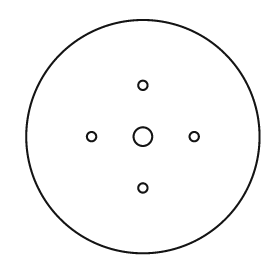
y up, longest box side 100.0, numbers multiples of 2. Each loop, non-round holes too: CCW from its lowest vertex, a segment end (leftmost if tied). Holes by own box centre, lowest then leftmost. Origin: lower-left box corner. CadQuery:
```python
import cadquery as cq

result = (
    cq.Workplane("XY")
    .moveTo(50.0, 50.0)
    .circle(50.0)
    .moveTo(50.0, 28.0)
    .circle(2.0)
    .moveTo(28.0, 50.0)
    .circle(2.0)
    .moveTo(50.0, 50.0)
    .circle(4.0)
    .moveTo(72.0, 50.0)
    .circle(2.0)
    .moveTo(50.0, 72.0)
    .circle(2.0)
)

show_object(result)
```